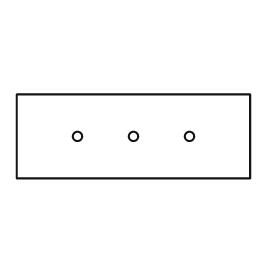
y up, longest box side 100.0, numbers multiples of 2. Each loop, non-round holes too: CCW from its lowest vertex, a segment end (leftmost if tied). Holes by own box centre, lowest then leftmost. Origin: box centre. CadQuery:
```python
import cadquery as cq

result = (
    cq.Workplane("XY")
    .moveTo(-50.0, -18.0)
    .lineTo(50.0, -18.0)
    .lineTo(50.0, 18.0)
    .lineTo(-50.0, 18.0)
    .close()
    .moveTo(-24.0, 0.0)
    .circle(2.0)
    .moveTo(0.0, 0.0)
    .circle(2.0)
    .moveTo(24.0, 0.0)
    .circle(2.0)
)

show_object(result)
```